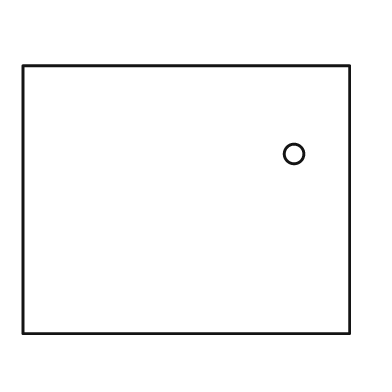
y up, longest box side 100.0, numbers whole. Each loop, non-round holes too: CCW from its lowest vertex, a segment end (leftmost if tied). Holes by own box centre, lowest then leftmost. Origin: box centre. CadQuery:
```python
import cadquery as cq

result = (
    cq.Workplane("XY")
    .moveTo(-50.0, -41.0)
    .lineTo(50.0, -41.0)
    .lineTo(50.0, 41.0)
    .lineTo(-50.0, 41.0)
    .close()
    .moveTo(33.0, 14.0)
    .circle(3.0)
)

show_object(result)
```